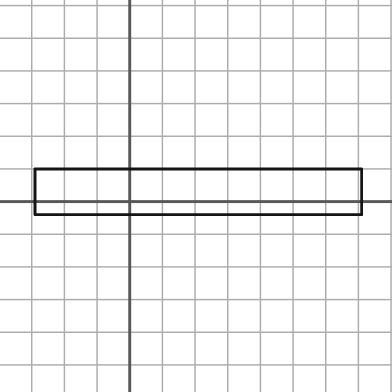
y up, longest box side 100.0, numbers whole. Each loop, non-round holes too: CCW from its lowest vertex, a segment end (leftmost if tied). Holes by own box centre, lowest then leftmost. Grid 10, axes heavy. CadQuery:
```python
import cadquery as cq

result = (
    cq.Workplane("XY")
    .moveTo(-29.0, -4.0)
    .lineTo(71.0, -4.0)
    .lineTo(71.0, 10.0)
    .lineTo(-29.0, 10.0)
    .close()
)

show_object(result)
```